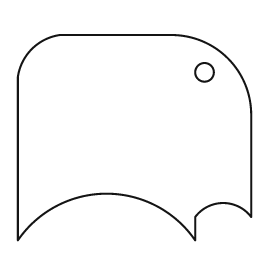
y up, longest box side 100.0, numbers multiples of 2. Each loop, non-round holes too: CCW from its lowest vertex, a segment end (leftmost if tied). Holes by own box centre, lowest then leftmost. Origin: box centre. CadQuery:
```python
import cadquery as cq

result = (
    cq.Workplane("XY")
    .moveTo(-50.0, -44.0)
    .threePointArc((-12.0, -24.0), (26.0, -44.0))
    .lineTo(26.0, -34.0)
    .threePointArc((38.0, -28.0), (50.0, -34.0))
    .lineTo(50.0, 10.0)
    .threePointArc((40.0, 34.0), (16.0, 44.0))
    .lineTo(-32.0, 44.0)
    .threePointArc((-44.0, 38.0), (-50.0, 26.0))
    .close()
    .moveTo(30.0, 28.0)
    .circle(4.0)
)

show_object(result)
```